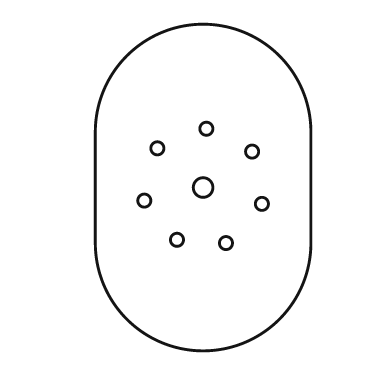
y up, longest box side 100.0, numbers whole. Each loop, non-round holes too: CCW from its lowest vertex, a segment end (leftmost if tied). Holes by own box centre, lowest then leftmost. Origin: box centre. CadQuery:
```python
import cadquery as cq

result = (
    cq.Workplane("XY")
    .moveTo(-33.0, -17.0)
    .threePointArc((0.0, -50.0), (33.0, -17.0))
    .lineTo(33.0, 17.0)
    .threePointArc((0.0, 50.0), (-33.0, 17.0))
    .close()
    .moveTo(7.0, -17.0)
    .circle(2.0)
    .moveTo(-8.0, -16.0)
    .circle(2.0)
    .moveTo(18.0, -5.0)
    .circle(2.0)
    .moveTo(-18.0, -4.0)
    .circle(2.0)
    .moveTo(0.0, 0.0)
    .circle(3.0)
    .moveTo(15.0, 11.0)
    .circle(2.0)
    .moveTo(-14.0, 12.0)
    .circle(2.0)
    .moveTo(1.0, 18.0)
    .circle(2.0)
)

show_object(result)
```